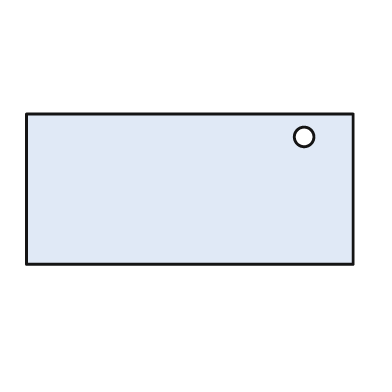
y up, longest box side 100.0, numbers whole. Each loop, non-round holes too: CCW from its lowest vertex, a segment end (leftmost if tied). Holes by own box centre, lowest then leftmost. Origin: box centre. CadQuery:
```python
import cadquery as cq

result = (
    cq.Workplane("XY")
    .moveTo(-50.0, -23.0)
    .lineTo(50.0, -23.0)
    .lineTo(50.0, 23.0)
    .lineTo(-50.0, 23.0)
    .close()
    .moveTo(35.0, 16.0)
    .circle(3.0)
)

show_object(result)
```